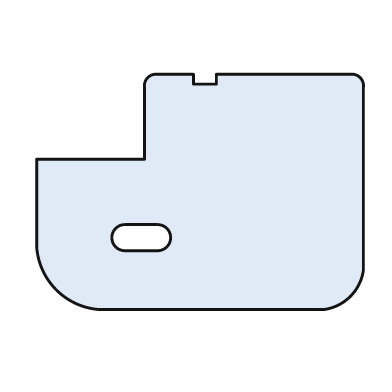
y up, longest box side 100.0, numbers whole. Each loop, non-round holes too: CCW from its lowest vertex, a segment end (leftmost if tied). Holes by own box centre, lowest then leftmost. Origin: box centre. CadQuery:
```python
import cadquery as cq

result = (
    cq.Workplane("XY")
    .moveTo(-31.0, -36.0)
    .lineTo(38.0, -36.0)
    .threePointArc((46.0, -32.0), (50.0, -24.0))
    .lineTo(50.0, 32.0)
    .threePointArc((49.0, 35.0), (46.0, 36.0))
    .lineTo(5.0, 36.0)
    .lineTo(5.0, 33.0)
    .lineTo(-2.0, 33.0)
    .lineTo(-2.0, 36.0)
    .lineTo(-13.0, 36.0)
    .threePointArc((-16.0, 35.0), (-17.0, 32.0))
    .lineTo(-17.0, 10.0)
    .lineTo(-50.0, 10.0)
    .lineTo(-50.0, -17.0)
    .threePointArc((-44.0, -30.0), (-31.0, -36.0))
    .close()
    .moveTo(-23.0, -18.0)
    .lineTo(-13.0, -18.0)
    .threePointArc((-9.0, -14.0), (-13.0, -10.0))
    .lineTo(-23.0, -10.0)
    .threePointArc((-27.0, -14.0), (-23.0, -18.0))
    .close()
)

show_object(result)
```